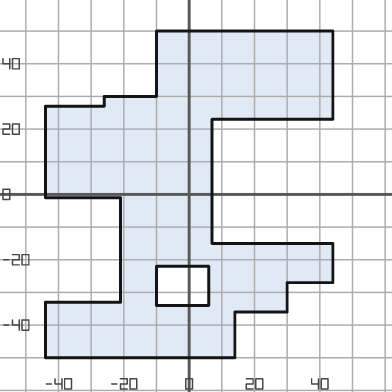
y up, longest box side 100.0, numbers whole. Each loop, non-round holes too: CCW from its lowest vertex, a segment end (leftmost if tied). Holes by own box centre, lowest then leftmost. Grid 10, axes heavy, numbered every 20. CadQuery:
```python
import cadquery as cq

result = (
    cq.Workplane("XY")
    .moveTo(-44.0, -50.0)
    .lineTo(14.0, -50.0)
    .lineTo(14.0, -36.0)
    .lineTo(30.0, -36.0)
    .lineTo(30.0, -27.0)
    .lineTo(44.0, -27.0)
    .lineTo(44.0, -15.0)
    .lineTo(7.0, -15.0)
    .lineTo(7.0, 23.0)
    .lineTo(44.0, 23.0)
    .lineTo(44.0, 50.0)
    .lineTo(-10.0, 50.0)
    .lineTo(-10.0, 30.0)
    .lineTo(-26.0, 30.0)
    .lineTo(-26.0, 27.0)
    .lineTo(-44.0, 27.0)
    .lineTo(-44.0, -1.0)
    .lineTo(-21.0, -1.0)
    .lineTo(-21.0, -33.0)
    .lineTo(-44.0, -33.0)
    .close()
    .moveTo(-10.0, -34.0)
    .lineTo(6.0, -34.0)
    .lineTo(6.0, -22.0)
    .lineTo(-10.0, -22.0)
    .close()
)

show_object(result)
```